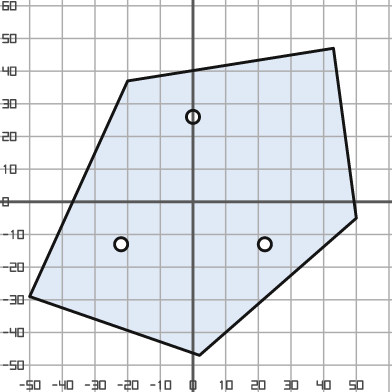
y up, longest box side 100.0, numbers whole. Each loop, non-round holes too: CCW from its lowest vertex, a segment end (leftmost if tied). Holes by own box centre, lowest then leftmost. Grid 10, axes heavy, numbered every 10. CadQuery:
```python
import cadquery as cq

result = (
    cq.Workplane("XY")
    .moveTo(2.0, -47.0)
    .lineTo(50.0, -5.0)
    .lineTo(43.0, 47.0)
    .lineTo(-20.0, 37.0)
    .lineTo(-50.0, -29.0)
    .close()
    .moveTo(-22.0, -13.0)
    .circle(2.0)
    .moveTo(22.0, -13.0)
    .circle(2.0)
    .moveTo(0.0, 26.0)
    .circle(2.0)
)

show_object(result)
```